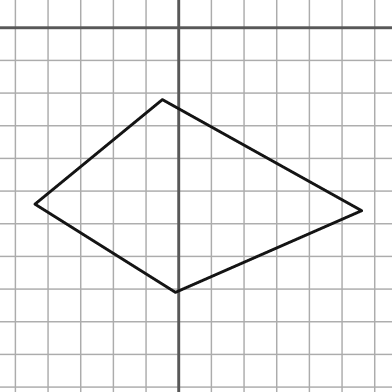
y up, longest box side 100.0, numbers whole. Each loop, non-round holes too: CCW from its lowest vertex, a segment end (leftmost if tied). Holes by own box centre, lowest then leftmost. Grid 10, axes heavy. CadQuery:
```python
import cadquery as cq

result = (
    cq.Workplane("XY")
    .moveTo(-1.0, -81.0)
    .lineTo(56.0, -56.0)
    .lineTo(-5.0, -22.0)
    .lineTo(-44.0, -54.0)
    .close()
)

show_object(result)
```